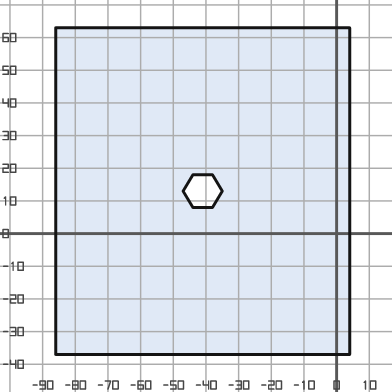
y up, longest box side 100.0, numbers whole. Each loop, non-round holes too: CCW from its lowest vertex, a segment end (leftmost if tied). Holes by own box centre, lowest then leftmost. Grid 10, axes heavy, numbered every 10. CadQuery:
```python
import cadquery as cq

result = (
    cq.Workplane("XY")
    .moveTo(-86.0, -37.0)
    .lineTo(4.0, -37.0)
    .lineTo(4.0, 63.0)
    .lineTo(-86.0, 63.0)
    .close()
    .moveTo(-44.0, 8.0)
    .lineTo(-38.0, 8.0)
    .lineTo(-35.0, 13.0)
    .lineTo(-38.0, 18.0)
    .lineTo(-44.0, 18.0)
    .lineTo(-47.0, 13.0)
    .close()
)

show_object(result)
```